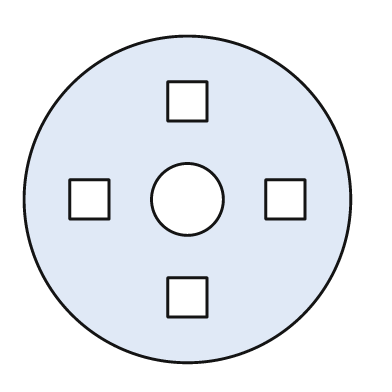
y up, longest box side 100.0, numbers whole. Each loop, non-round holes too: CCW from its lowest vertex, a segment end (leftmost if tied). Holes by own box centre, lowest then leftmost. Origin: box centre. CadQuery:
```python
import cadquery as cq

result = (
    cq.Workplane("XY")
    .moveTo(0.0, 0.0)
    .circle(50.0)
    .moveTo(-6.0, -36.0)
    .lineTo(6.0, -36.0)
    .lineTo(6.0, -24.0)
    .lineTo(-6.0, -24.0)
    .close()
    .moveTo(-36.0, -6.0)
    .lineTo(-24.0, -6.0)
    .lineTo(-24.0, 6.0)
    .lineTo(-36.0, 6.0)
    .close()
    .moveTo(0.0, 0.0)
    .circle(11.0)
    .moveTo(24.0, -6.0)
    .lineTo(36.0, -6.0)
    .lineTo(36.0, 6.0)
    .lineTo(24.0, 6.0)
    .close()
    .moveTo(-6.0, 24.0)
    .lineTo(6.0, 24.0)
    .lineTo(6.0, 36.0)
    .lineTo(-6.0, 36.0)
    .close()
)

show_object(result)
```